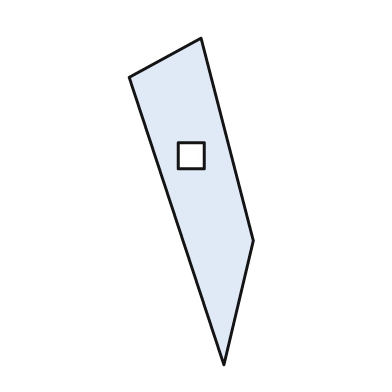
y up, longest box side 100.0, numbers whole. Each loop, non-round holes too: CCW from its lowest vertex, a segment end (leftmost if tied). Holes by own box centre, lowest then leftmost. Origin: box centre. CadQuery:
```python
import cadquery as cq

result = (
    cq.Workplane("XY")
    .moveTo(10.0, -50.0)
    .lineTo(19.0, -12.0)
    .lineTo(3.0, 50.0)
    .lineTo(-19.0, 38.0)
    .close()
    .moveTo(-4.0, 10.0)
    .lineTo(4.0, 10.0)
    .lineTo(4.0, 18.0)
    .lineTo(-4.0, 18.0)
    .close()
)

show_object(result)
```